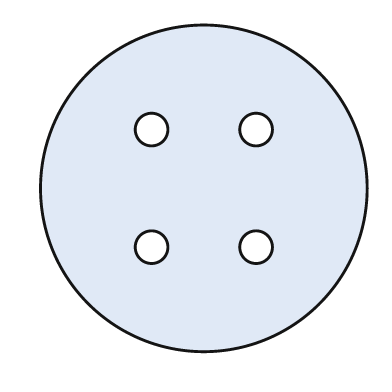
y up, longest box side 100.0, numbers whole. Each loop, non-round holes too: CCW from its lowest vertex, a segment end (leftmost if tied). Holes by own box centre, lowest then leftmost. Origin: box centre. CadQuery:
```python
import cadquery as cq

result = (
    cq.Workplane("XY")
    .moveTo(0.0, 0.0)
    .circle(50.0)
    .moveTo(-16.0, -18.0)
    .circle(5.0)
    .moveTo(16.0, -18.0)
    .circle(5.0)
    .moveTo(-16.0, 18.0)
    .circle(5.0)
    .moveTo(16.0, 18.0)
    .circle(5.0)
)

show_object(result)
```